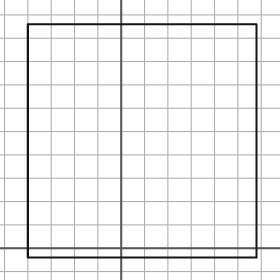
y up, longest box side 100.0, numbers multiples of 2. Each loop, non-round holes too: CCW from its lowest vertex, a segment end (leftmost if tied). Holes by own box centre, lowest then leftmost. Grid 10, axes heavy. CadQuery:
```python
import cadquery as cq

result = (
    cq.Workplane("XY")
    .moveTo(-40.0, -4.0)
    .lineTo(58.0, -4.0)
    .lineTo(58.0, 96.0)
    .lineTo(-40.0, 96.0)
    .close()
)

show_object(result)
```